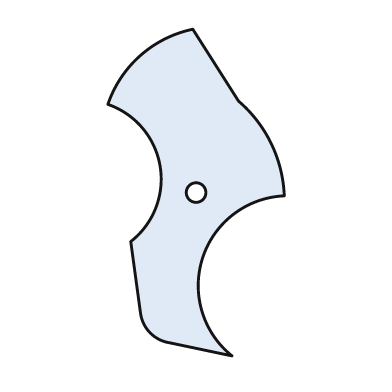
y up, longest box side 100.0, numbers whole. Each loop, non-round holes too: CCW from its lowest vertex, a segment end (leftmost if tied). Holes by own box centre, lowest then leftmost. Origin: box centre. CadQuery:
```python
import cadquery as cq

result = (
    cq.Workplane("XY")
    .moveTo(11.0, -50.0)
    .threePointArc((2.0, -20.0), (27.0, -1.0))
    .threePointArc((23.0, 15.0), (13.0, 28.0))
    .lineTo(-1.0, 50.0)
    .threePointArc((-17.0, 42.0), (-27.0, 27.0))
    .threePointArc((-11.0, 8.0), (-20.0, -15.0))
    .lineTo(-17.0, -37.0)
    .threePointArc((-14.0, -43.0), (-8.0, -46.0))
    .close()
    .moveTo(0.0, 0.0)
    .circle(3.0)
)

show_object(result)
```